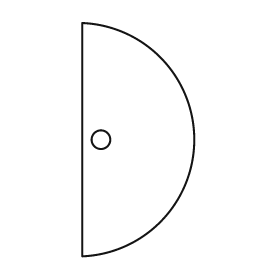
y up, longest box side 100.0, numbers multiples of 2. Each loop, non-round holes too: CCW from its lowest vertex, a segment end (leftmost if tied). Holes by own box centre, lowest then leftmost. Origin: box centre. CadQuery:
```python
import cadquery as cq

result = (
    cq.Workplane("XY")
    .moveTo(-24.0, -50.0)
    .threePointArc((24.0, 0.0), (-24.0, 50.0))
    .close()
    .moveTo(-16.0, 0.0)
    .circle(4.0)
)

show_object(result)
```